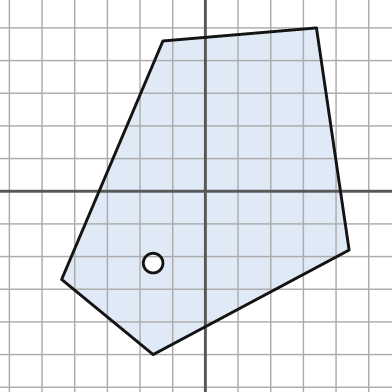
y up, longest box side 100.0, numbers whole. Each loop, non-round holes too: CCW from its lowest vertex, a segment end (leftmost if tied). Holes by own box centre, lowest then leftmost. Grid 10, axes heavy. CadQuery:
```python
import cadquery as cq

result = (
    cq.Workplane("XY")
    .moveTo(-16.0, -50.0)
    .lineTo(44.0, -18.0)
    .lineTo(34.0, 50.0)
    .lineTo(-13.0, 46.0)
    .lineTo(-44.0, -27.0)
    .close()
    .moveTo(-16.0, -22.0)
    .circle(3.0)
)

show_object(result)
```